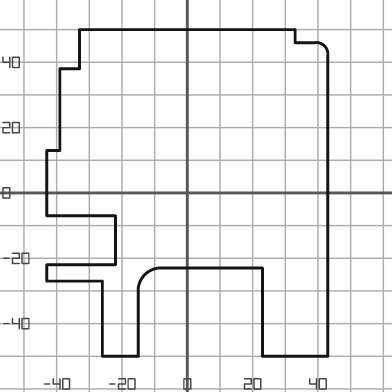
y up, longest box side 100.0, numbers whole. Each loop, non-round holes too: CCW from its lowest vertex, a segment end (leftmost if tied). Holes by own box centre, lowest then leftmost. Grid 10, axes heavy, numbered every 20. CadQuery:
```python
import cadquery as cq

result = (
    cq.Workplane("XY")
    .moveTo(-26.0, -50.0)
    .lineTo(-15.0, -50.0)
    .lineTo(-15.0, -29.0)
    .threePointArc((-13.0, -25.0), (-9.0, -23.0))
    .lineTo(23.0, -23.0)
    .lineTo(23.0, -50.0)
    .lineTo(43.0, -50.0)
    .lineTo(43.0, 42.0)
    .threePointArc((42.0, 45.0), (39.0, 46.0))
    .lineTo(33.0, 46.0)
    .lineTo(33.0, 50.0)
    .lineTo(-33.0, 50.0)
    .lineTo(-33.0, 38.0)
    .lineTo(-39.0, 38.0)
    .lineTo(-39.0, 13.0)
    .lineTo(-43.0, 13.0)
    .lineTo(-43.0, -7.0)
    .lineTo(-22.0, -7.0)
    .lineTo(-22.0, -22.0)
    .lineTo(-43.0, -22.0)
    .lineTo(-43.0, -27.0)
    .lineTo(-26.0, -27.0)
    .close()
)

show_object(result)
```